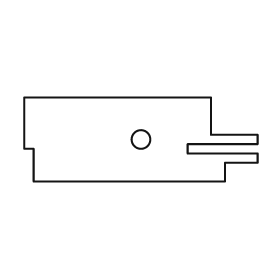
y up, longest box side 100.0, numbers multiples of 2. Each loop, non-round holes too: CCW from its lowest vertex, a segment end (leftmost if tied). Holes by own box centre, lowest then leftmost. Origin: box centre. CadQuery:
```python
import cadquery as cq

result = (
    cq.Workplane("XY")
    .moveTo(-46.0, -18.0)
    .lineTo(36.0, -18.0)
    .lineTo(36.0, -10.0)
    .lineTo(50.0, -10.0)
    .lineTo(50.0, -6.0)
    .lineTo(20.0, -6.0)
    .lineTo(20.0, -2.0)
    .lineTo(50.0, -2.0)
    .lineTo(50.0, 2.0)
    .lineTo(30.0, 2.0)
    .lineTo(30.0, 18.0)
    .lineTo(-50.0, 18.0)
    .lineTo(-50.0, -4.0)
    .lineTo(-46.0, -4.0)
    .close()
    .moveTo(0.0, 0.0)
    .circle(4.0)
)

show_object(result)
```